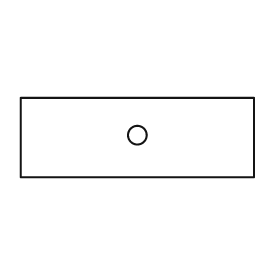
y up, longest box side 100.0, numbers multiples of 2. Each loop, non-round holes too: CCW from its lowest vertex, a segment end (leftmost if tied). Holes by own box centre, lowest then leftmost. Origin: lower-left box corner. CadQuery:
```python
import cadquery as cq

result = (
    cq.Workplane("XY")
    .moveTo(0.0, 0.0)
    .lineTo(100.0, 0.0)
    .lineTo(100.0, 34.0)
    .lineTo(0.0, 34.0)
    .close()
    .moveTo(50.0, 18.0)
    .circle(4.0)
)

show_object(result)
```